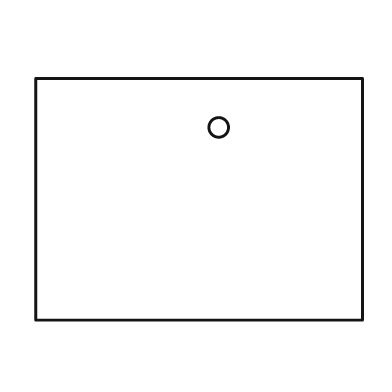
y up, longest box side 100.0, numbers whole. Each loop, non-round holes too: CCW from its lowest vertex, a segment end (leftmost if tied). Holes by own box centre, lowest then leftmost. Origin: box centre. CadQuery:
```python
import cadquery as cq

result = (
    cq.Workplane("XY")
    .moveTo(-50.0, -37.0)
    .lineTo(50.0, -37.0)
    .lineTo(50.0, 37.0)
    .lineTo(-50.0, 37.0)
    .close()
    .moveTo(6.0, 22.0)
    .circle(3.0)
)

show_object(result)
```